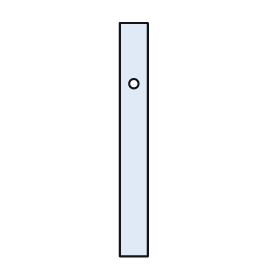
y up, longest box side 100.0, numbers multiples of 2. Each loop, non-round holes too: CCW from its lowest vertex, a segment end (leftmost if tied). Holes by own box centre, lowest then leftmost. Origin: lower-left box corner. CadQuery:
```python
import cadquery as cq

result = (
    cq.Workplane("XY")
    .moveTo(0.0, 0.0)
    .lineTo(12.0, 0.0)
    .lineTo(12.0, 100.0)
    .lineTo(0.0, 100.0)
    .close()
    .moveTo(6.0, 74.0)
    .circle(2.0)
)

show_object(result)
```